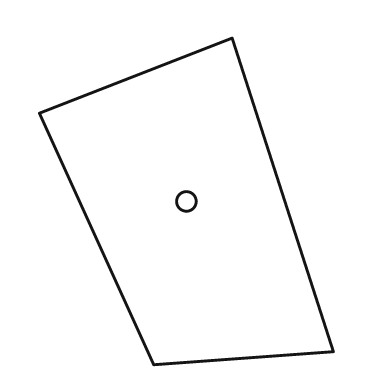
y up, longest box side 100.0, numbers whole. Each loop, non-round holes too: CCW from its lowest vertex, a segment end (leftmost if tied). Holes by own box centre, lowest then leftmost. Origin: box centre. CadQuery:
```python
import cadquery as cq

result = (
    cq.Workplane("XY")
    .moveTo(-10.0, -50.0)
    .lineTo(45.0, -46.0)
    .lineTo(14.0, 50.0)
    .lineTo(-45.0, 27.0)
    .close()
    .moveTo(0.0, 0.0)
    .circle(3.0)
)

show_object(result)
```